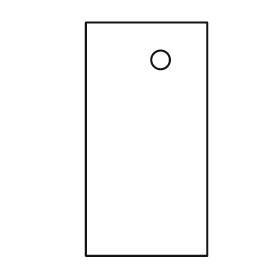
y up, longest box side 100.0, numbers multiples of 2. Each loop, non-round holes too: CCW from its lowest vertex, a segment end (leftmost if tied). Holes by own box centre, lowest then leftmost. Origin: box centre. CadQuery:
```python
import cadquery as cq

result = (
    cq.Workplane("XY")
    .moveTo(-26.0, -50.0)
    .lineTo(26.0, -50.0)
    .lineTo(26.0, 50.0)
    .lineTo(-26.0, 50.0)
    .close()
    .moveTo(6.0, 34.0)
    .circle(4.0)
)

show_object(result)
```